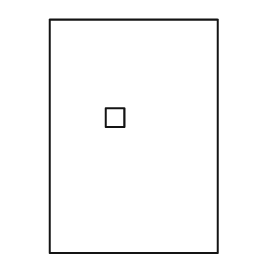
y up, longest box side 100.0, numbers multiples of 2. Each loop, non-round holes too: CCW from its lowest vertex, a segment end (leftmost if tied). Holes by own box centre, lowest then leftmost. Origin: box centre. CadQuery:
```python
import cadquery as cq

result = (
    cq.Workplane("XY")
    .moveTo(-36.0, -50.0)
    .lineTo(36.0, -50.0)
    .lineTo(36.0, 50.0)
    .lineTo(-36.0, 50.0)
    .close()
    .moveTo(-12.0, 4.0)
    .lineTo(-4.0, 4.0)
    .lineTo(-4.0, 12.0)
    .lineTo(-12.0, 12.0)
    .close()
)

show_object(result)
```